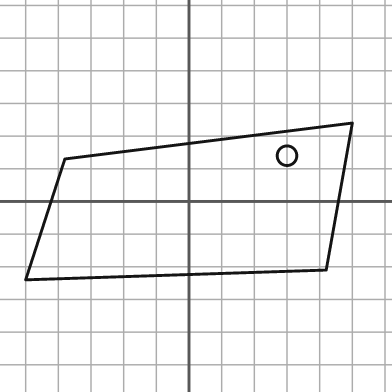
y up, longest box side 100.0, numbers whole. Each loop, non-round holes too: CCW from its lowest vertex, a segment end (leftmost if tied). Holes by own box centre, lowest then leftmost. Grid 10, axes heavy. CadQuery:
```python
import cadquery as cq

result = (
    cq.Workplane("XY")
    .moveTo(-50.0, -24.0)
    .lineTo(42.0, -21.0)
    .lineTo(50.0, 24.0)
    .lineTo(-38.0, 13.0)
    .close()
    .moveTo(30.0, 14.0)
    .circle(3.0)
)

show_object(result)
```